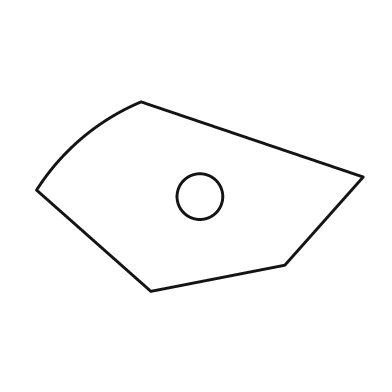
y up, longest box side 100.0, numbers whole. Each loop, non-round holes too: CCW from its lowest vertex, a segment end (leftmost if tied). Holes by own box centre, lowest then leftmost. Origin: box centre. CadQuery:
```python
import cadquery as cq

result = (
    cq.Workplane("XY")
    .moveTo(-15.0, -29.0)
    .lineTo(26.0, -21.0)
    .lineTo(50.0, 6.0)
    .lineTo(-18.0, 29.0)
    .threePointArc((-36.0, 18.0), (-50.0, 2.0))
    .close()
    .moveTo(0.0, 0.0)
    .circle(7.0)
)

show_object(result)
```